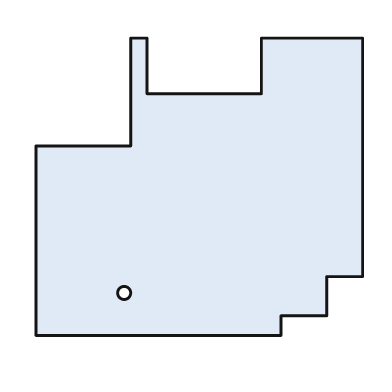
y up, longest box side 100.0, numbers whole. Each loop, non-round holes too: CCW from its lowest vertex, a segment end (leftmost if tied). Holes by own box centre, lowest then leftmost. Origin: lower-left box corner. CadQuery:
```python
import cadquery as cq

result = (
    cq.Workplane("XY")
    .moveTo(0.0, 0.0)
    .lineTo(75.0, 0.0)
    .lineTo(75.0, 6.0)
    .lineTo(89.0, 6.0)
    .lineTo(89.0, 18.0)
    .lineTo(100.0, 18.0)
    .lineTo(100.0, 91.0)
    .lineTo(69.0, 91.0)
    .lineTo(69.0, 74.0)
    .lineTo(34.0, 74.0)
    .lineTo(34.0, 91.0)
    .lineTo(29.0, 91.0)
    .lineTo(29.0, 58.0)
    .lineTo(0.0, 58.0)
    .close()
    .moveTo(27.0, 13.0)
    .circle(2.0)
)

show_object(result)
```